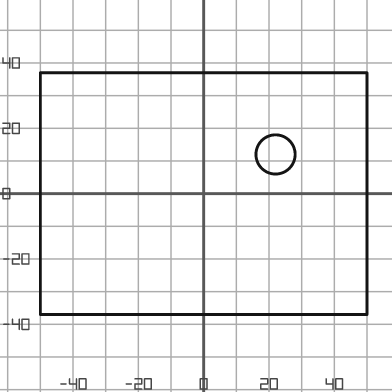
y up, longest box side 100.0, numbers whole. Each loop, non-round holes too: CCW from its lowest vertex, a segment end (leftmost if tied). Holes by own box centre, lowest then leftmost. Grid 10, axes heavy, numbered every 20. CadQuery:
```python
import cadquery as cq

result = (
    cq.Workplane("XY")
    .moveTo(-50.0, -37.0)
    .lineTo(50.0, -37.0)
    .lineTo(50.0, 37.0)
    .lineTo(-50.0, 37.0)
    .close()
    .moveTo(22.0, 12.0)
    .circle(6.0)
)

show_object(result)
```